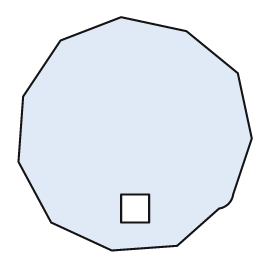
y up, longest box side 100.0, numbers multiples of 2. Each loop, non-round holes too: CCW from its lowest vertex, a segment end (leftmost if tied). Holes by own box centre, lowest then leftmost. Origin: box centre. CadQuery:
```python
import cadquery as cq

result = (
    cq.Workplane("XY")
    .moveTo(-10.0, -50.0)
    .lineTo(18.0, -48.0)
    .lineTo(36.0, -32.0)
    .threePointArc((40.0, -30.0), (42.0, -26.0))
    .lineTo(50.0, -2.0)
    .lineTo(44.0, 26.0)
    .lineTo(22.0, 44.0)
    .lineTo(-6.0, 50.0)
    .lineTo(-32.0, 40.0)
    .lineTo(-48.0, 16.0)
    .lineTo(-50.0, -12.0)
    .lineTo(-36.0, -38.0)
    .close()
    .moveTo(-6.0, -38.0)
    .lineTo(6.0, -38.0)
    .lineTo(6.0, -26.0)
    .lineTo(-6.0, -26.0)
    .close()
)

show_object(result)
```